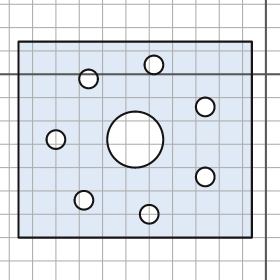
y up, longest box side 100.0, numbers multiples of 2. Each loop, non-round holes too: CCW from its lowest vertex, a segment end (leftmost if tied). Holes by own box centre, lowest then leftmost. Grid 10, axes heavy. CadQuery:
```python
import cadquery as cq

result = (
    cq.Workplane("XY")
    .moveTo(-106.0, -70.0)
    .lineTo(-6.0, -70.0)
    .lineTo(-6.0, 14.0)
    .lineTo(-106.0, 14.0)
    .close()
    .moveTo(-50.0, -60.0)
    .circle(4.0)
    .moveTo(-78.0, -54.0)
    .circle(4.0)
    .moveTo(-26.0, -44.0)
    .circle(4.0)
    .moveTo(-90.0, -28.0)
    .circle(4.0)
    .moveTo(-56.0, -28.0)
    .circle(12.0)
    .moveTo(-26.0, -14.0)
    .circle(4.0)
    .moveTo(-76.0, -2.0)
    .circle(4.0)
    .moveTo(-48.0, 4.0)
    .circle(4.0)
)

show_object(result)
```